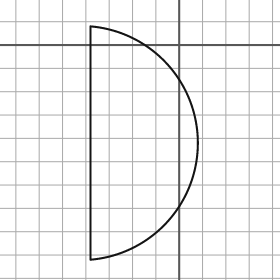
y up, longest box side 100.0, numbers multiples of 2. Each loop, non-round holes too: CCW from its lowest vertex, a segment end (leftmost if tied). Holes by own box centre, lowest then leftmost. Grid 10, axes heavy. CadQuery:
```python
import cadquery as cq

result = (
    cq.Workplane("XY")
    .moveTo(-38.0, -92.0)
    .threePointArc((8.0, -42.0), (-38.0, 8.0))
    .close()
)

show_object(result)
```